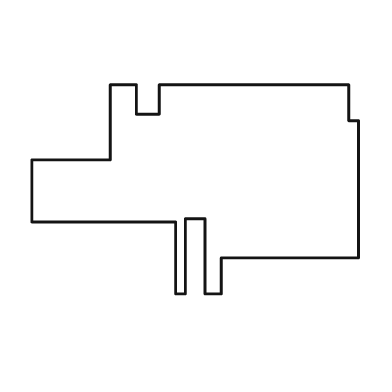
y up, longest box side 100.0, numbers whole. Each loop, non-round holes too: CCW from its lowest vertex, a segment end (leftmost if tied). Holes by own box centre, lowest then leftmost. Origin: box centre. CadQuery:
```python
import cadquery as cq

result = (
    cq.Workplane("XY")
    .moveTo(-6.0, -32.0)
    .lineTo(-3.0, -32.0)
    .lineTo(-3.0, -9.0)
    .lineTo(3.0, -9.0)
    .lineTo(3.0, -32.0)
    .lineTo(8.0, -32.0)
    .lineTo(8.0, -21.0)
    .lineTo(50.0, -21.0)
    .lineTo(50.0, 21.0)
    .lineTo(47.0, 21.0)
    .lineTo(47.0, 32.0)
    .lineTo(-11.0, 32.0)
    .lineTo(-11.0, 23.0)
    .lineTo(-18.0, 23.0)
    .lineTo(-18.0, 32.0)
    .lineTo(-26.0, 32.0)
    .lineTo(-26.0, 9.0)
    .lineTo(-50.0, 9.0)
    .lineTo(-50.0, -10.0)
    .lineTo(-6.0, -10.0)
    .close()
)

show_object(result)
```